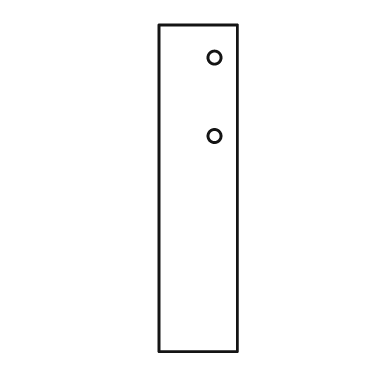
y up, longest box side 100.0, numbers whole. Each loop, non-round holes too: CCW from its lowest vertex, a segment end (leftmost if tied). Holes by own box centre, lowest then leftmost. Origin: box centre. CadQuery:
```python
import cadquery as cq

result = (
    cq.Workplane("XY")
    .moveTo(-12.0, -50.0)
    .lineTo(12.0, -50.0)
    .lineTo(12.0, 50.0)
    .lineTo(-12.0, 50.0)
    .close()
    .moveTo(5.0, 16.0)
    .circle(2.0)
    .moveTo(5.0, 40.0)
    .circle(2.0)
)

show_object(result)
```